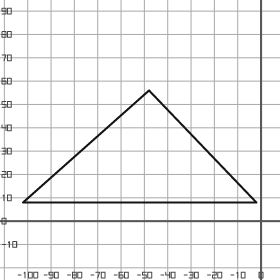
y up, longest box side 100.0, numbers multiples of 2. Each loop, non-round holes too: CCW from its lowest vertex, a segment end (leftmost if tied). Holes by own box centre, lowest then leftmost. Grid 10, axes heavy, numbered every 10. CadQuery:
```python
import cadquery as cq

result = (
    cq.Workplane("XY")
    .moveTo(-102.0, 8.0)
    .lineTo(-2.0, 8.0)
    .lineTo(-48.0, 56.0)
    .close()
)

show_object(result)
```